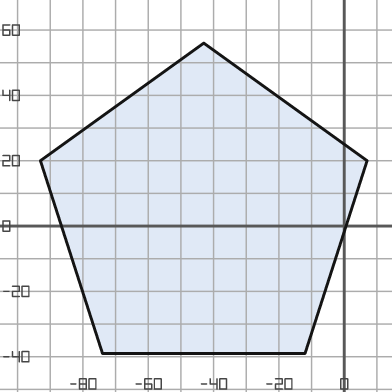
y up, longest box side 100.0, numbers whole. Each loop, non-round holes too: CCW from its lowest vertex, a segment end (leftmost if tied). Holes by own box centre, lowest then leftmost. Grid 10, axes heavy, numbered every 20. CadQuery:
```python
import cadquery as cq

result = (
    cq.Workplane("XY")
    .moveTo(-74.0, -39.0)
    .lineTo(-12.0, -39.0)
    .lineTo(7.0, 20.0)
    .lineTo(-43.0, 56.0)
    .lineTo(-93.0, 20.0)
    .close()
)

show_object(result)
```